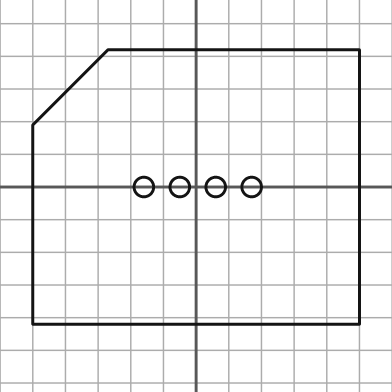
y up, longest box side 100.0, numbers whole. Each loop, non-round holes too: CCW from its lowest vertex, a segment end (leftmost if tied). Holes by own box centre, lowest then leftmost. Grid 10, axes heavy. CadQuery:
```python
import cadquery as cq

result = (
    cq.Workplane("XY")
    .moveTo(-50.0, -42.0)
    .lineTo(50.0, -42.0)
    .lineTo(50.0, 42.0)
    .lineTo(-27.0, 42.0)
    .lineTo(-50.0, 19.0)
    .close()
    .moveTo(-16.0, 0.0)
    .circle(3.0)
    .moveTo(-5.0, 0.0)
    .circle(3.0)
    .moveTo(6.0, 0.0)
    .circle(3.0)
    .moveTo(17.0, 0.0)
    .circle(3.0)
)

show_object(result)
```